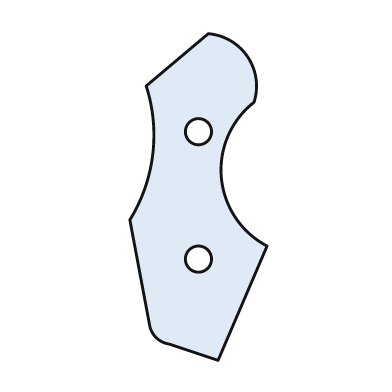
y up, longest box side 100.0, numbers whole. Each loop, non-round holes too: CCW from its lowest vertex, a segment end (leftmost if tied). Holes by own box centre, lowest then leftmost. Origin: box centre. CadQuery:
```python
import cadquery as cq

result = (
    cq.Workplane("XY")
    .moveTo(6.0, -50.0)
    .lineTo(21.0, -15.0)
    .threePointArc((7.0, 6.0), (17.0, 29.0))
    .threePointArc((15.0, 43.0), (3.0, 50.0))
    .lineTo(-16.0, 34.0)
    .threePointArc((-14.0, 13.0), (-21.0, -7.0))
    .lineTo(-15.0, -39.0)
    .threePointArc((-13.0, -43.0), (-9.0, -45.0))
    .close()
    .moveTo(0.0, -19.0)
    .circle(4.0)
    .moveTo(0.0, 20.0)
    .circle(4.0)
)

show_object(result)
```